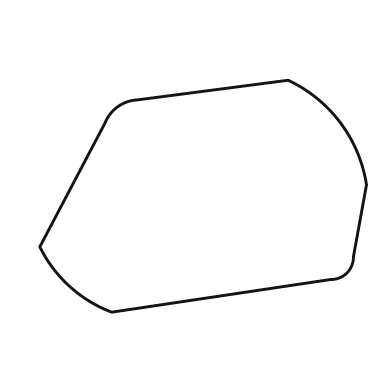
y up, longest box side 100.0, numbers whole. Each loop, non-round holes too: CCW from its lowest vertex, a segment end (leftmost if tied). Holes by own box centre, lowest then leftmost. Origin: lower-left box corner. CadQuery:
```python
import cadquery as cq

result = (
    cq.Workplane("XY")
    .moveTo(22.0, 0.0)
    .lineTo(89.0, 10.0)
    .threePointArc((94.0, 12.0), (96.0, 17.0))
    .lineTo(100.0, 39.0)
    .threePointArc((92.0, 58.0), (76.0, 71.0))
    .lineTo(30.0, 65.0)
    .threePointArc((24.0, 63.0), (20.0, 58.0))
    .lineTo(0.0, 20.0)
    .threePointArc((9.0, 8.0), (22.0, 0.0))
    .close()
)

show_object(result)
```